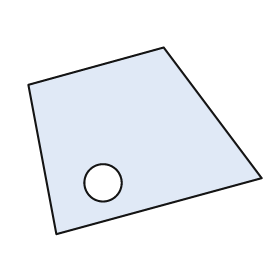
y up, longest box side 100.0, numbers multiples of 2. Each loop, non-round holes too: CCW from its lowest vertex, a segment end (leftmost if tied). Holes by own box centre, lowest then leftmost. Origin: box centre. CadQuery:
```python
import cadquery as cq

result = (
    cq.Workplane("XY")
    .moveTo(-38.0, -40.0)
    .lineTo(50.0, -16.0)
    .lineTo(8.0, 40.0)
    .lineTo(-50.0, 24.0)
    .close()
    .moveTo(-18.0, -18.0)
    .circle(8.0)
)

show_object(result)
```